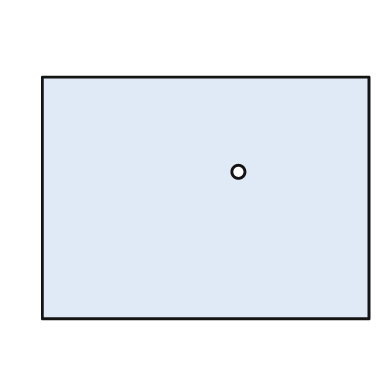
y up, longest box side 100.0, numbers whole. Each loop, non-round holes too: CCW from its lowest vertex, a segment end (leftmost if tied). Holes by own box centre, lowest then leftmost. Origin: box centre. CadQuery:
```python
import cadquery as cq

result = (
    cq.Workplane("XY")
    .moveTo(-50.0, -37.0)
    .lineTo(50.0, -37.0)
    .lineTo(50.0, 37.0)
    .lineTo(-50.0, 37.0)
    .close()
    .moveTo(10.0, 8.0)
    .circle(2.0)
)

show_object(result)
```